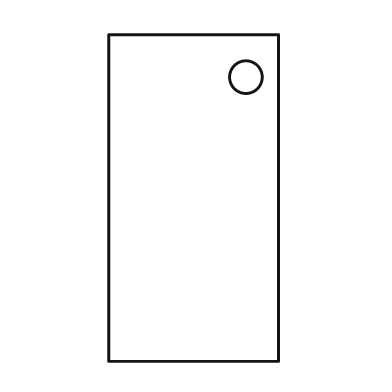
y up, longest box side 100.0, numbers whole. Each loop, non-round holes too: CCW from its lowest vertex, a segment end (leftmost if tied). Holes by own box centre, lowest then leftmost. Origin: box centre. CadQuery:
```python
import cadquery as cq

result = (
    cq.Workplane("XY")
    .moveTo(-26.0, -50.0)
    .lineTo(26.0, -50.0)
    .lineTo(26.0, 50.0)
    .lineTo(-26.0, 50.0)
    .close()
    .moveTo(16.0, 37.0)
    .circle(5.0)
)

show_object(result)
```